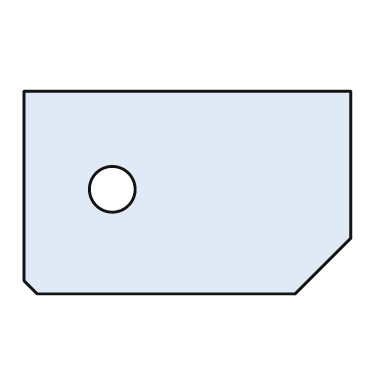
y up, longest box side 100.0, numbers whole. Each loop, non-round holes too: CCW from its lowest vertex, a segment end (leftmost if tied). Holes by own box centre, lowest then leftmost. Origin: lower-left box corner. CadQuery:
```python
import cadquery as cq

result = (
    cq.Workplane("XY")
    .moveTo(4.0, 0.0)
    .lineTo(83.0, 0.0)
    .lineTo(100.0, 17.0)
    .lineTo(100.0, 62.0)
    .lineTo(0.0, 62.0)
    .lineTo(0.0, 4.0)
    .close()
    .moveTo(27.0, 32.0)
    .circle(7.0)
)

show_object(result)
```